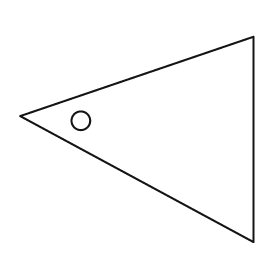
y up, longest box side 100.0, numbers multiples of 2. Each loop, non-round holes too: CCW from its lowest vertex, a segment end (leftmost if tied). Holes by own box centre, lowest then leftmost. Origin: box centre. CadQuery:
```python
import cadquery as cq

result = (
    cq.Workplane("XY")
    .moveTo(50.0, -44.0)
    .lineTo(50.0, 44.0)
    .lineTo(-50.0, 10.0)
    .close()
    .moveTo(-24.0, 8.0)
    .circle(4.0)
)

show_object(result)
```